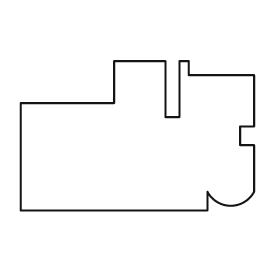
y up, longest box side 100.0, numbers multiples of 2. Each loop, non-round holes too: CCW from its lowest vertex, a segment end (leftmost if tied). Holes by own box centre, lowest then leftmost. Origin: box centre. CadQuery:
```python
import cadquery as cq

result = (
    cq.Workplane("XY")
    .moveTo(-50.0, -32.0)
    .lineTo(30.0, -32.0)
    .lineTo(30.0, -24.0)
    .threePointArc((40.0, -30.0), (50.0, -24.0))
    .lineTo(50.0, -4.0)
    .lineTo(44.0, -4.0)
    .lineTo(44.0, 4.0)
    .lineTo(50.0, 4.0)
    .lineTo(50.0, 26.0)
    .lineTo(22.0, 26.0)
    .lineTo(22.0, 32.0)
    .lineTo(18.0, 32.0)
    .lineTo(18.0, 8.0)
    .lineTo(12.0, 8.0)
    .lineTo(12.0, 32.0)
    .lineTo(-10.0, 32.0)
    .lineTo(-10.0, 14.0)
    .lineTo(-50.0, 14.0)
    .close()
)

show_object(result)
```